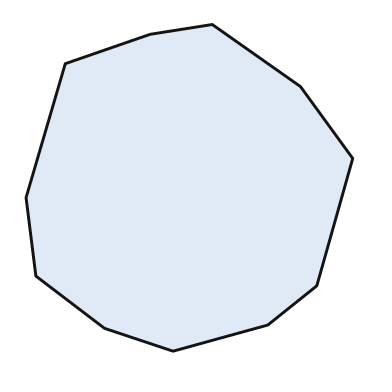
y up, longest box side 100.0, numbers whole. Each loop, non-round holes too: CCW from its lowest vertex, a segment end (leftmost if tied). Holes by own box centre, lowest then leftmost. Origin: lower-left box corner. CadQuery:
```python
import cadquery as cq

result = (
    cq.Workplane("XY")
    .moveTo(45.0, 0.0)
    .lineTo(74.0, 8.0)
    .lineTo(89.0, 20.0)
    .lineTo(100.0, 59.0)
    .lineTo(84.0, 81.0)
    .lineTo(57.0, 100.0)
    .lineTo(38.0, 97.0)
    .lineTo(12.0, 88.0)
    .lineTo(0.0, 47.0)
    .lineTo(3.0, 23.0)
    .lineTo(24.0, 7.0)
    .close()
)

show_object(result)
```